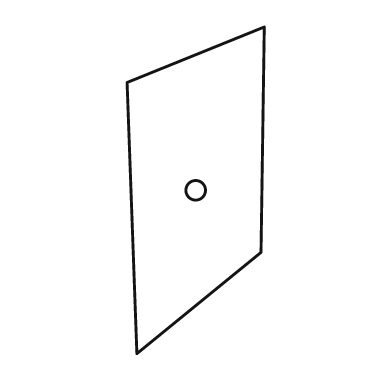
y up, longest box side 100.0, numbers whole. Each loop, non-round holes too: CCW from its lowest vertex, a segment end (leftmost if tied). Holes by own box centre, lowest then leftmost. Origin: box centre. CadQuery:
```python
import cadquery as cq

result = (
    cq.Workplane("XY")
    .moveTo(-18.0, -50.0)
    .lineTo(20.0, -19.0)
    .lineTo(21.0, 50.0)
    .lineTo(-21.0, 33.0)
    .close()
    .moveTo(0.0, 0.0)
    .circle(3.0)
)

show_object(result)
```